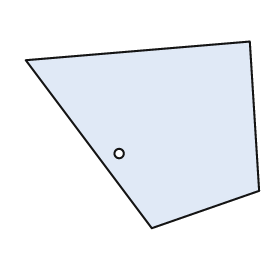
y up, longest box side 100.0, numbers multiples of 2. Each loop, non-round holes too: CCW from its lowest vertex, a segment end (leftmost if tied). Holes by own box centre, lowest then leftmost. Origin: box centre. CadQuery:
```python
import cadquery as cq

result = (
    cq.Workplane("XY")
    .moveTo(4.0, -40.0)
    .lineTo(50.0, -24.0)
    .lineTo(46.0, 40.0)
    .lineTo(-50.0, 32.0)
    .close()
    .moveTo(-10.0, -8.0)
    .circle(2.0)
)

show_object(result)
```